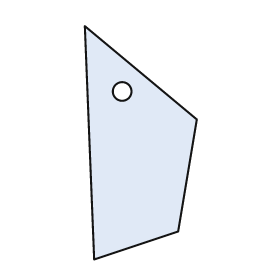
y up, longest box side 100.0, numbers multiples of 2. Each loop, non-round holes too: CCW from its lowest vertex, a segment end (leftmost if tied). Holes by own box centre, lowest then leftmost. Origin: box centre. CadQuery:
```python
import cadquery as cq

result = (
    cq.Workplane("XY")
    .moveTo(-20.0, -50.0)
    .lineTo(16.0, -38.0)
    .lineTo(24.0, 10.0)
    .lineTo(-24.0, 50.0)
    .close()
    .moveTo(-8.0, 22.0)
    .circle(4.0)
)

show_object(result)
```